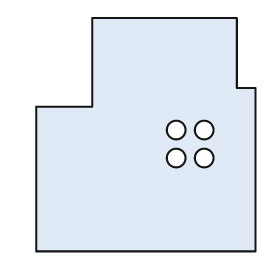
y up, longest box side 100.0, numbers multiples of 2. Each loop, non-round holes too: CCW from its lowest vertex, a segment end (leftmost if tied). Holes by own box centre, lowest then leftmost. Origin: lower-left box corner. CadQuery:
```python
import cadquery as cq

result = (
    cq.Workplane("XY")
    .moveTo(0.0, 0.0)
    .lineTo(94.0, 0.0)
    .lineTo(94.0, 70.0)
    .lineTo(86.0, 70.0)
    .lineTo(86.0, 100.0)
    .lineTo(24.0, 100.0)
    .lineTo(24.0, 62.0)
    .lineTo(0.0, 62.0)
    .close()
    .moveTo(60.0, 40.0)
    .circle(4.0)
    .moveTo(72.0, 40.0)
    .circle(4.0)
    .moveTo(60.0, 52.0)
    .circle(4.0)
    .moveTo(72.0, 52.0)
    .circle(4.0)
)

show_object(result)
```